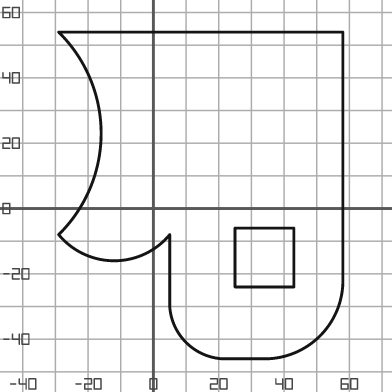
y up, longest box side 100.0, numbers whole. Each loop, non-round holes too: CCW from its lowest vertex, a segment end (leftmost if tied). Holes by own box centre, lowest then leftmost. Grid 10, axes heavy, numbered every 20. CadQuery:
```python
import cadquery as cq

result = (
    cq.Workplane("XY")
    .moveTo(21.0, -46.0)
    .lineTo(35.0, -46.0)
    .threePointArc((51.0, -39.0), (58.0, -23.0))
    .lineTo(58.0, 54.0)
    .lineTo(-29.0, 54.0)
    .threePointArc((-16.0, 23.0), (-29.0, -8.0))
    .threePointArc((-12.0, -16.0), (5.0, -8.0))
    .lineTo(5.0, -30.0)
    .threePointArc((10.0, -41.0), (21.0, -46.0))
    .close()
    .moveTo(25.0, -24.0)
    .lineTo(43.0, -24.0)
    .lineTo(43.0, -6.0)
    .lineTo(25.0, -6.0)
    .close()
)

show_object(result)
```